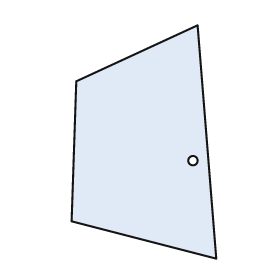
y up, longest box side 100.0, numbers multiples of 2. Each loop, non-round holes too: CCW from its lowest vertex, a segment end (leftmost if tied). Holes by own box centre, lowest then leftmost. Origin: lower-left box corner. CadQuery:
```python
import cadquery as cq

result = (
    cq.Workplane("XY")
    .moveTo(62.0, 0.0)
    .lineTo(54.0, 100.0)
    .lineTo(2.0, 76.0)
    .lineTo(0.0, 16.0)
    .close()
    .moveTo(52.0, 42.0)
    .circle(2.0)
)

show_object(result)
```